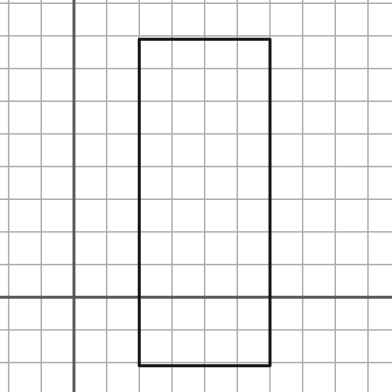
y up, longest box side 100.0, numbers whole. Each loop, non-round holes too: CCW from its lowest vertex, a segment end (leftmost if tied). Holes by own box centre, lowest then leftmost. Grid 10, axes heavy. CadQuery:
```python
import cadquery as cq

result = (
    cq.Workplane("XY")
    .moveTo(20.0, -21.0)
    .lineTo(60.0, -21.0)
    .lineTo(60.0, 79.0)
    .lineTo(20.0, 79.0)
    .close()
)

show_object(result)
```